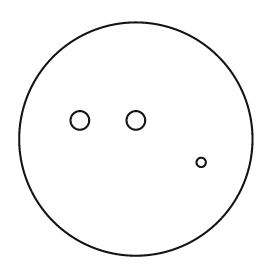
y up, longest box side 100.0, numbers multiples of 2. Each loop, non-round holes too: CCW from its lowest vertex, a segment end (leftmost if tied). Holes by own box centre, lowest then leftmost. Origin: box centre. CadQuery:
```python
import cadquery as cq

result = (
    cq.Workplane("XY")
    .moveTo(0.0, 0.0)
    .circle(50.0)
    .moveTo(28.0, -10.0)
    .circle(2.0)
    .moveTo(-24.0, 8.0)
    .circle(4.0)
    .moveTo(0.0, 8.0)
    .circle(4.0)
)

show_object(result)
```